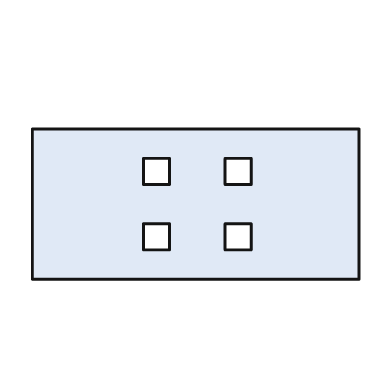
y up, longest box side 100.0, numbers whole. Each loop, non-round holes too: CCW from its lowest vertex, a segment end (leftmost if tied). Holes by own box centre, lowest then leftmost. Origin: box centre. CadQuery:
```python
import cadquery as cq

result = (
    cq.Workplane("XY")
    .moveTo(-50.0, -23.0)
    .lineTo(50.0, -23.0)
    .lineTo(50.0, 23.0)
    .lineTo(-50.0, 23.0)
    .close()
    .moveTo(-16.0, -14.0)
    .lineTo(-8.0, -14.0)
    .lineTo(-8.0, -6.0)
    .lineTo(-16.0, -6.0)
    .close()
    .moveTo(9.0, -14.0)
    .lineTo(17.0, -14.0)
    .lineTo(17.0, -6.0)
    .lineTo(9.0, -6.0)
    .close()
    .moveTo(-16.0, 6.0)
    .lineTo(-8.0, 6.0)
    .lineTo(-8.0, 14.0)
    .lineTo(-16.0, 14.0)
    .close()
    .moveTo(9.0, 6.0)
    .lineTo(17.0, 6.0)
    .lineTo(17.0, 14.0)
    .lineTo(9.0, 14.0)
    .close()
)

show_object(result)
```